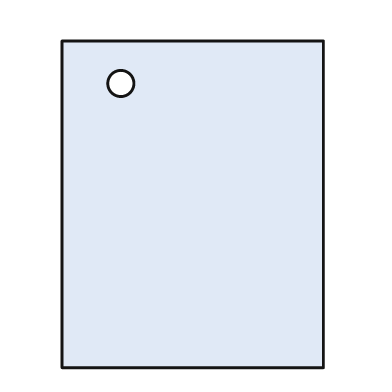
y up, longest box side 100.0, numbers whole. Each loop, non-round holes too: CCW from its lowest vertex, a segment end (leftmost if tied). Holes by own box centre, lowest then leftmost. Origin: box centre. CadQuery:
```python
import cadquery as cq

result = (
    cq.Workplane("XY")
    .moveTo(-40.0, -50.0)
    .lineTo(40.0, -50.0)
    .lineTo(40.0, 50.0)
    .lineTo(-40.0, 50.0)
    .close()
    .moveTo(-22.0, 37.0)
    .circle(4.0)
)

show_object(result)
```